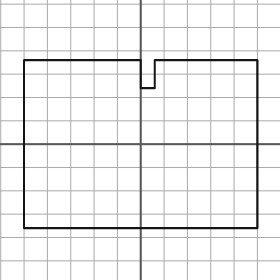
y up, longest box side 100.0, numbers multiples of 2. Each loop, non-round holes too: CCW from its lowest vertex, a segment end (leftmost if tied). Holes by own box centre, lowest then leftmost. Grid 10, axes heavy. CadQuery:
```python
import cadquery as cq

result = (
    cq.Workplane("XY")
    .moveTo(-50.0, -36.0)
    .lineTo(50.0, -36.0)
    .lineTo(50.0, 36.0)
    .lineTo(6.0, 36.0)
    .lineTo(6.0, 24.0)
    .lineTo(0.0, 24.0)
    .lineTo(0.0, 36.0)
    .lineTo(-50.0, 36.0)
    .close()
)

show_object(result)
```